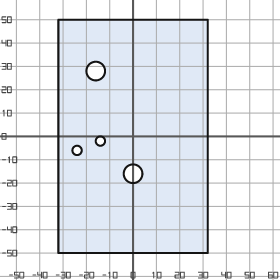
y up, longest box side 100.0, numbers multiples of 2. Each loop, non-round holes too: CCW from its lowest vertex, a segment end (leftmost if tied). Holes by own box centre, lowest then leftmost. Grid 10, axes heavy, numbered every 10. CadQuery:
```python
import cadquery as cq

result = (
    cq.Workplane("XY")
    .moveTo(-32.0, -50.0)
    .lineTo(32.0, -50.0)
    .lineTo(32.0, 50.0)
    .lineTo(-32.0, 50.0)
    .close()
    .moveTo(0.0, -16.0)
    .circle(4.0)
    .moveTo(-24.0, -6.0)
    .circle(2.0)
    .moveTo(-14.0, -2.0)
    .circle(2.0)
    .moveTo(-16.0, 28.0)
    .circle(4.0)
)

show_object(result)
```